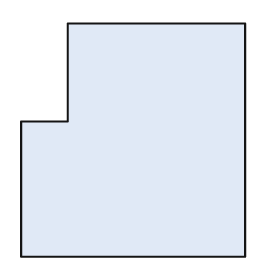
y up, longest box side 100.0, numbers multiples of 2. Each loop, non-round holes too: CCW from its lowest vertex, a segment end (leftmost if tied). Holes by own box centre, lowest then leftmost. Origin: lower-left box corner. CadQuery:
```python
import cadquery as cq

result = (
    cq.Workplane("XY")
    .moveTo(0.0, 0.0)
    .lineTo(96.0, 0.0)
    .lineTo(96.0, 100.0)
    .lineTo(20.0, 100.0)
    .lineTo(20.0, 58.0)
    .lineTo(0.0, 58.0)
    .close()
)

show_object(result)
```